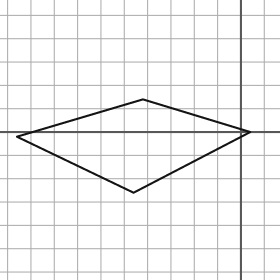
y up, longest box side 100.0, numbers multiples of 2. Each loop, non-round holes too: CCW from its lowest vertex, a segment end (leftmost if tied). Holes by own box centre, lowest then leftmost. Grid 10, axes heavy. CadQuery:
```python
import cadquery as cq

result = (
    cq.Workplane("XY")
    .moveTo(-46.0, -26.0)
    .lineTo(4.0, 0.0)
    .lineTo(-42.0, 14.0)
    .lineTo(-96.0, -2.0)
    .close()
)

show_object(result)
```